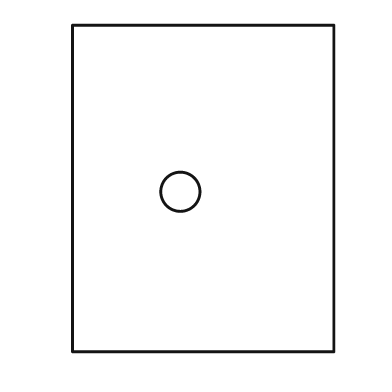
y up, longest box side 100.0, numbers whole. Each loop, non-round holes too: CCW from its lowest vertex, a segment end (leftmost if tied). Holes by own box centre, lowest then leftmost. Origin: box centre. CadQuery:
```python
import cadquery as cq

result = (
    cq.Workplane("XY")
    .moveTo(-40.0, -50.0)
    .lineTo(40.0, -50.0)
    .lineTo(40.0, 50.0)
    .lineTo(-40.0, 50.0)
    .close()
    .moveTo(-7.0, -1.0)
    .circle(6.0)
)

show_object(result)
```